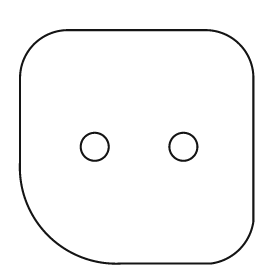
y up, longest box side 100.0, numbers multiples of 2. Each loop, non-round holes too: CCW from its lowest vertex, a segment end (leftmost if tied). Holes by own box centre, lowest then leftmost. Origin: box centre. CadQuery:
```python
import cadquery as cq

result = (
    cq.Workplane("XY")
    .moveTo(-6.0, -50.0)
    .lineTo(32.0, -50.0)
    .threePointArc((44.0, -44.0), (50.0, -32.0))
    .lineTo(50.0, 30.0)
    .threePointArc((44.0, 44.0), (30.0, 50.0))
    .lineTo(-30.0, 50.0)
    .threePointArc((-44.0, 44.0), (-50.0, 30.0))
    .lineTo(-50.0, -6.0)
    .threePointArc((-38.0, -38.0), (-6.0, -50.0))
    .close()
    .moveTo(-18.0, 0.0)
    .circle(6.0)
    .moveTo(20.0, 0.0)
    .circle(6.0)
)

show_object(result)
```